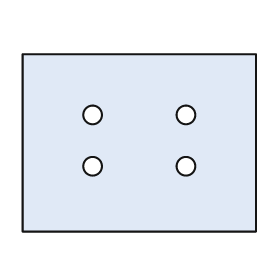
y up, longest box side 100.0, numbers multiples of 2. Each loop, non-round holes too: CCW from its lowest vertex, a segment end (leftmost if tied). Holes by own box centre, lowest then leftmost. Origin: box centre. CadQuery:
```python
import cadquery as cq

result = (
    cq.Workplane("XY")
    .moveTo(-50.0, -38.0)
    .lineTo(50.0, -38.0)
    .lineTo(50.0, 38.0)
    .lineTo(-50.0, 38.0)
    .close()
    .moveTo(-20.0, -10.0)
    .circle(4.0)
    .moveTo(20.0, -10.0)
    .circle(4.0)
    .moveTo(-20.0, 12.0)
    .circle(4.0)
    .moveTo(20.0, 12.0)
    .circle(4.0)
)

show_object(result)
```